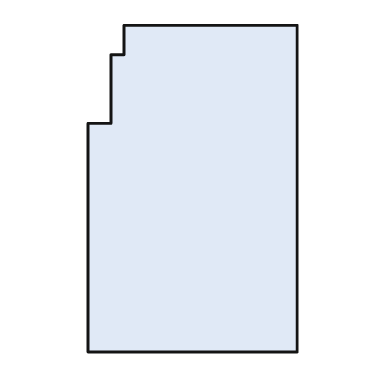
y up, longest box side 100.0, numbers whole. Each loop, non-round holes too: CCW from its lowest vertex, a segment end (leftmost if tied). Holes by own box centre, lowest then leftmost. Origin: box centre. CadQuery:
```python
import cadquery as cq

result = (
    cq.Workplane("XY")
    .moveTo(-32.0, -50.0)
    .lineTo(32.0, -50.0)
    .lineTo(32.0, 50.0)
    .lineTo(-21.0, 50.0)
    .lineTo(-21.0, 41.0)
    .lineTo(-25.0, 41.0)
    .lineTo(-25.0, 20.0)
    .lineTo(-32.0, 20.0)
    .close()
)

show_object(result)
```